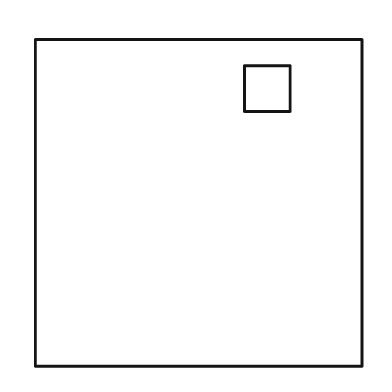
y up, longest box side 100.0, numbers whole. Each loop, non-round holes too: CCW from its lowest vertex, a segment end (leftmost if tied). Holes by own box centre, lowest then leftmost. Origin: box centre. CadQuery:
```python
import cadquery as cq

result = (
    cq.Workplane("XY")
    .moveTo(-50.0, -50.0)
    .lineTo(50.0, -50.0)
    .lineTo(50.0, 50.0)
    .lineTo(-50.0, 50.0)
    .close()
    .moveTo(14.0, 28.0)
    .lineTo(28.0, 28.0)
    .lineTo(28.0, 42.0)
    .lineTo(14.0, 42.0)
    .close()
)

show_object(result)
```